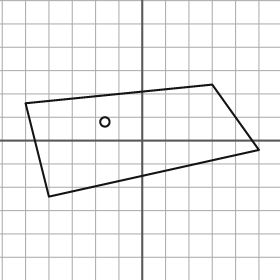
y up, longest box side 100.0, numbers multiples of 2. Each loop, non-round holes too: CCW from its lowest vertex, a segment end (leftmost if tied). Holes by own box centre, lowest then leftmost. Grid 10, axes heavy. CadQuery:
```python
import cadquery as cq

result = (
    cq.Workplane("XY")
    .moveTo(-40.0, -24.0)
    .lineTo(50.0, -4.0)
    .lineTo(30.0, 24.0)
    .lineTo(-50.0, 16.0)
    .close()
    .moveTo(-16.0, 8.0)
    .circle(2.0)
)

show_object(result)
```